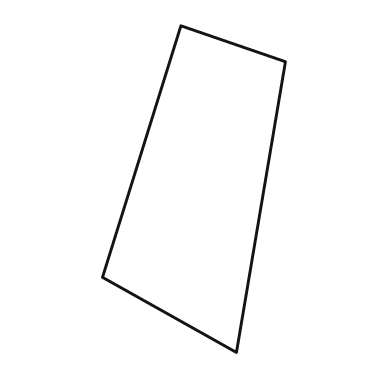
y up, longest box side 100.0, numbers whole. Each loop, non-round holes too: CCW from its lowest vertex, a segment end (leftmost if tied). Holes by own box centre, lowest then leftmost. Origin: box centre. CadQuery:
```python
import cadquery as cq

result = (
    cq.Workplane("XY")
    .moveTo(13.0, -50.0)
    .lineTo(28.0, 39.0)
    .lineTo(-4.0, 50.0)
    .lineTo(-28.0, -27.0)
    .close()
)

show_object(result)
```